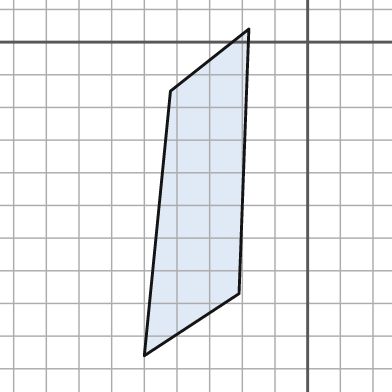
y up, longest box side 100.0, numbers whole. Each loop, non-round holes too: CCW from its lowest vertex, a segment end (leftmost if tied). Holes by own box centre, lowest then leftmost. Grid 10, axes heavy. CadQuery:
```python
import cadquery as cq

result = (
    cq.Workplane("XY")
    .moveTo(-50.0, -96.0)
    .lineTo(-21.0, -77.0)
    .lineTo(-18.0, 4.0)
    .lineTo(-42.0, -15.0)
    .close()
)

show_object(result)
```